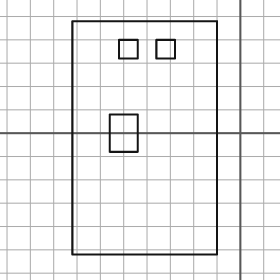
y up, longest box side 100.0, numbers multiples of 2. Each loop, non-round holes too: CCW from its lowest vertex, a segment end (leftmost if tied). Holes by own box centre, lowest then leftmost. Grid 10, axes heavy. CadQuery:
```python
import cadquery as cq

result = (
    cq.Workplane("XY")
    .moveTo(-72.0, -52.0)
    .lineTo(-10.0, -52.0)
    .lineTo(-10.0, 48.0)
    .lineTo(-72.0, 48.0)
    .close()
    .moveTo(-56.0, -8.0)
    .lineTo(-44.0, -8.0)
    .lineTo(-44.0, 8.0)
    .lineTo(-56.0, 8.0)
    .close()
    .moveTo(-52.0, 32.0)
    .lineTo(-44.0, 32.0)
    .lineTo(-44.0, 40.0)
    .lineTo(-52.0, 40.0)
    .close()
    .moveTo(-36.0, 32.0)
    .lineTo(-28.0, 32.0)
    .lineTo(-28.0, 40.0)
    .lineTo(-36.0, 40.0)
    .close()
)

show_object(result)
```